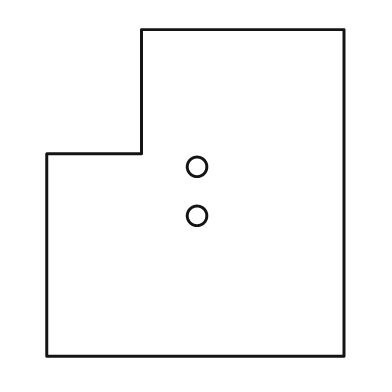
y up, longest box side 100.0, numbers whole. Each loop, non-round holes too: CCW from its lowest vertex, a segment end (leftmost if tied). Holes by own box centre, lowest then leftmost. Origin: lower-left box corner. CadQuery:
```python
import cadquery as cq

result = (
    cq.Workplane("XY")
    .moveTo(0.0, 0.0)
    .lineTo(91.0, 0.0)
    .lineTo(91.0, 100.0)
    .lineTo(29.0, 100.0)
    .lineTo(29.0, 62.0)
    .lineTo(0.0, 62.0)
    .close()
    .moveTo(46.0, 43.0)
    .circle(3.0)
    .moveTo(46.0, 58.0)
    .circle(3.0)
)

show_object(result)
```